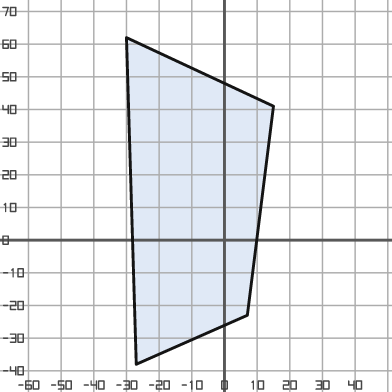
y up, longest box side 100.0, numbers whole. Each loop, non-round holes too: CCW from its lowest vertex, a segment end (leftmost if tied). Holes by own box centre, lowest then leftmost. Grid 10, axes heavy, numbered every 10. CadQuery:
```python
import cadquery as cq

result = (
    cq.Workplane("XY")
    .moveTo(-27.0, -38.0)
    .lineTo(7.0, -23.0)
    .lineTo(15.0, 41.0)
    .lineTo(-30.0, 62.0)
    .close()
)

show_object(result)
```